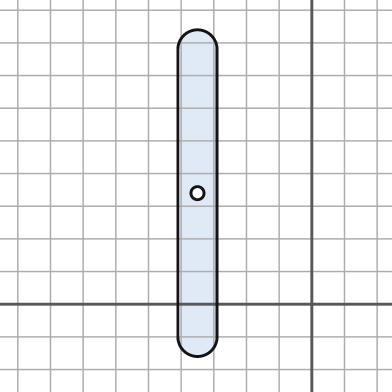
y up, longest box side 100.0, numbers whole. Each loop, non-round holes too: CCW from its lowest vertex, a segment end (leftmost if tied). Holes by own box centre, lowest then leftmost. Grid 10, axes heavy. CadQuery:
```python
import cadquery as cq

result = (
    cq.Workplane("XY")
    .moveTo(-41.0, -10.0)
    .threePointArc((-35.0, -16.0), (-29.0, -10.0))
    .lineTo(-29.0, 78.0)
    .threePointArc((-35.0, 84.0), (-41.0, 78.0))
    .close()
    .moveTo(-35.0, 34.0)
    .circle(2.0)
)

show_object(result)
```